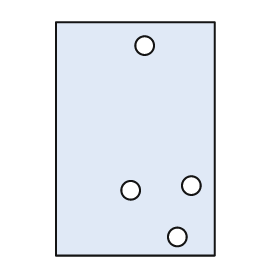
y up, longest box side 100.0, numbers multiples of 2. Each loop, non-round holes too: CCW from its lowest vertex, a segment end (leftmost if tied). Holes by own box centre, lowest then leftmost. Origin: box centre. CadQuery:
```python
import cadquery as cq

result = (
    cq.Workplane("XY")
    .moveTo(-34.0, -50.0)
    .lineTo(34.0, -50.0)
    .lineTo(34.0, 50.0)
    .lineTo(-34.0, 50.0)
    .close()
    .moveTo(18.0, -42.0)
    .circle(4.0)
    .moveTo(-2.0, -22.0)
    .circle(4.0)
    .moveTo(24.0, -20.0)
    .circle(4.0)
    .moveTo(4.0, 40.0)
    .circle(4.0)
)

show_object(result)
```